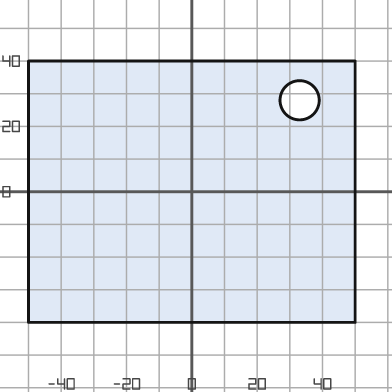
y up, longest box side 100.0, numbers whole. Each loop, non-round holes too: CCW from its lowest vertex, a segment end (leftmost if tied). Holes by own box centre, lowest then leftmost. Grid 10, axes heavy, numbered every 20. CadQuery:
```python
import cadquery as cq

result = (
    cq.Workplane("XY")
    .moveTo(-50.0, -40.0)
    .lineTo(50.0, -40.0)
    .lineTo(50.0, 40.0)
    .lineTo(-50.0, 40.0)
    .close()
    .moveTo(33.0, 28.0)
    .circle(6.0)
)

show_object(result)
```